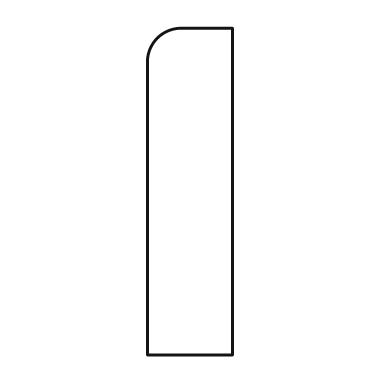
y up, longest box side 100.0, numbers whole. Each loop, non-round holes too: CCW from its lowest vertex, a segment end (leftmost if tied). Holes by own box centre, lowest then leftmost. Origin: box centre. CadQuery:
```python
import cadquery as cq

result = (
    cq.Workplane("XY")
    .moveTo(-13.0, -50.0)
    .lineTo(13.0, -50.0)
    .lineTo(13.0, 50.0)
    .lineTo(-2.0, 50.0)
    .threePointArc((-10.0, 47.0), (-13.0, 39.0))
    .close()
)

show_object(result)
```